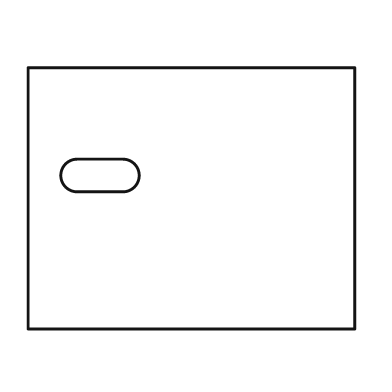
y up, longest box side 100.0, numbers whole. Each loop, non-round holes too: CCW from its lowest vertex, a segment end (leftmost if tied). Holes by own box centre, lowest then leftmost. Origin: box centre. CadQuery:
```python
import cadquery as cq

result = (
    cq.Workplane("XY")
    .moveTo(-50.0, -40.0)
    .lineTo(50.0, -40.0)
    .lineTo(50.0, 40.0)
    .lineTo(-50.0, 40.0)
    .close()
    .moveTo(-35.0, 2.0)
    .lineTo(-21.0, 2.0)
    .threePointArc((-16.0, 7.0), (-21.0, 12.0))
    .lineTo(-35.0, 12.0)
    .threePointArc((-40.0, 7.0), (-35.0, 2.0))
    .close()
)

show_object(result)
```